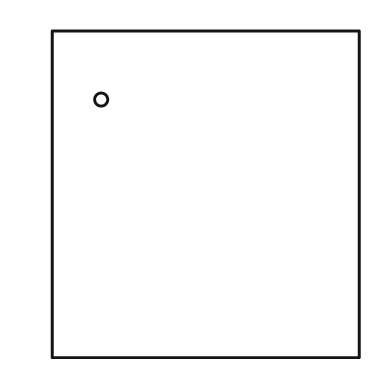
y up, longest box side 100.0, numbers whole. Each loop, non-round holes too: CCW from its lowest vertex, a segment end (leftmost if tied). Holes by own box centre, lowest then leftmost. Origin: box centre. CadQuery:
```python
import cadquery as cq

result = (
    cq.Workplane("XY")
    .moveTo(-47.0, -50.0)
    .lineTo(47.0, -50.0)
    .lineTo(47.0, 50.0)
    .lineTo(-47.0, 50.0)
    .close()
    .moveTo(-32.0, 29.0)
    .circle(2.0)
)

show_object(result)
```